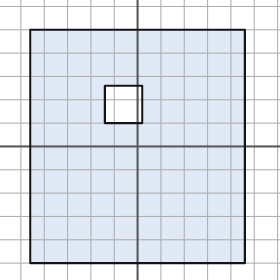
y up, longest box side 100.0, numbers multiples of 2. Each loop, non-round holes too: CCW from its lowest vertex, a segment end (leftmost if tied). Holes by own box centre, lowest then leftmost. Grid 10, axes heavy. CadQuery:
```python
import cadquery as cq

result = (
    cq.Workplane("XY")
    .moveTo(-46.0, -50.0)
    .lineTo(46.0, -50.0)
    .lineTo(46.0, 50.0)
    .lineTo(-46.0, 50.0)
    .close()
    .moveTo(-14.0, 10.0)
    .lineTo(2.0, 10.0)
    .lineTo(2.0, 26.0)
    .lineTo(-14.0, 26.0)
    .close()
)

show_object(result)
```